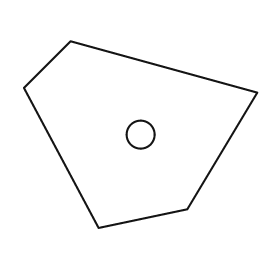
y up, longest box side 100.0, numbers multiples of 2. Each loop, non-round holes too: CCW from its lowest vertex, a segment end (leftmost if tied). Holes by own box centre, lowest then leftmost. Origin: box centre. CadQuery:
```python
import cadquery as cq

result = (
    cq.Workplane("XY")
    .moveTo(-18.0, -40.0)
    .lineTo(20.0, -32.0)
    .lineTo(50.0, 18.0)
    .lineTo(-30.0, 40.0)
    .lineTo(-50.0, 20.0)
    .close()
    .moveTo(0.0, 0.0)
    .circle(6.0)
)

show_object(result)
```